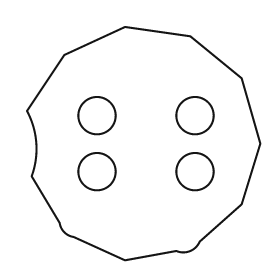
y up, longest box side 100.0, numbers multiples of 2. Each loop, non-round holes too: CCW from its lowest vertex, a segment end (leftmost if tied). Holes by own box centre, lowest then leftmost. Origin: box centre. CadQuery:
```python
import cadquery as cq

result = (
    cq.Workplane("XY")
    .moveTo(-8.0, -50.0)
    .lineTo(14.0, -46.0)
    .threePointArc((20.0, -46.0), (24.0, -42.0))
    .lineTo(42.0, -26.0)
    .lineTo(50.0, 0.0)
    .lineTo(42.0, 28.0)
    .lineTo(20.0, 46.0)
    .lineTo(-8.0, 50.0)
    .lineTo(-34.0, 38.0)
    .lineTo(-50.0, 14.0)
    .threePointArc((-46.0, 0.0), (-48.0, -14.0))
    .lineTo(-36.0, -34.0)
    .threePointArc((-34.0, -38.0), (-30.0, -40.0))
    .close()
    .moveTo(-20.0, -12.0)
    .circle(8.0)
    .moveTo(22.0, -12.0)
    .circle(8.0)
    .moveTo(-20.0, 12.0)
    .circle(8.0)
    .moveTo(22.0, 12.0)
    .circle(8.0)
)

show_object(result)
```